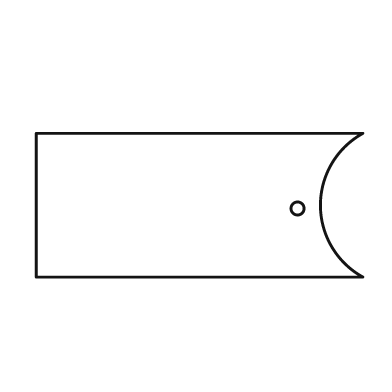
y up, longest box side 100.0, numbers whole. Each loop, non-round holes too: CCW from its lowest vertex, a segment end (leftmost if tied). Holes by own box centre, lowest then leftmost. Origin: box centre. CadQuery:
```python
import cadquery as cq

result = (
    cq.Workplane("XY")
    .moveTo(-50.0, -22.0)
    .lineTo(50.0, -22.0)
    .threePointArc((37.0, 0.0), (50.0, 22.0))
    .lineTo(-50.0, 22.0)
    .close()
    .moveTo(30.0, -1.0)
    .circle(2.0)
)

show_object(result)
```